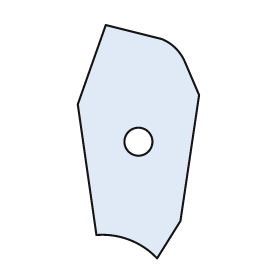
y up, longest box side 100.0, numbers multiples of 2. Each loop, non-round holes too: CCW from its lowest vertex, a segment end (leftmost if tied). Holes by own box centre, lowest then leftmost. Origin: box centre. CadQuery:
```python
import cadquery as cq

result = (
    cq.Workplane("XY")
    .moveTo(8.0, -50.0)
    .lineTo(18.0, -34.0)
    .lineTo(26.0, 20.0)
    .lineTo(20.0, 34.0)
    .threePointArc((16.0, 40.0), (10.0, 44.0))
    .lineTo(-14.0, 50.0)
    .lineTo(-26.0, 16.0)
    .lineTo(-18.0, -40.0)
    .threePointArc((-4.0, -42.0), (8.0, -50.0))
    .close()
    .moveTo(0.0, 0.0)
    .circle(6.0)
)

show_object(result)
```